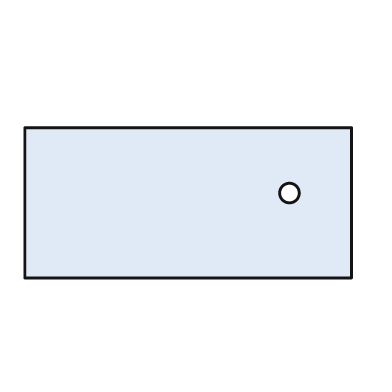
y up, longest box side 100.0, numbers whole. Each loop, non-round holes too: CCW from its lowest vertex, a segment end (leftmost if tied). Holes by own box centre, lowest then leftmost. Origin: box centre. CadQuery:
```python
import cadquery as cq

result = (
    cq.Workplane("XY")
    .moveTo(-50.0, -23.0)
    .lineTo(50.0, -23.0)
    .lineTo(50.0, 23.0)
    .lineTo(-50.0, 23.0)
    .close()
    .moveTo(31.0, 3.0)
    .circle(3.0)
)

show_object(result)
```